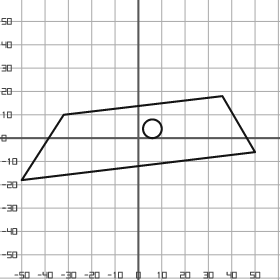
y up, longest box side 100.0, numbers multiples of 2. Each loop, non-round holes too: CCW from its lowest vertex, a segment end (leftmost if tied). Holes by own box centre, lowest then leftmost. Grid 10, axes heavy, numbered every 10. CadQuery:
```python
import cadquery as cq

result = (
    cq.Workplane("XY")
    .moveTo(-50.0, -18.0)
    .lineTo(50.0, -6.0)
    .lineTo(36.0, 18.0)
    .lineTo(-32.0, 10.0)
    .close()
    .moveTo(6.0, 4.0)
    .circle(4.0)
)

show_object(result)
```